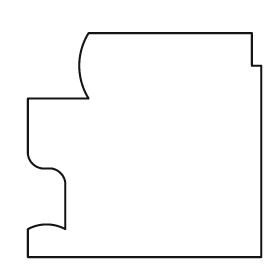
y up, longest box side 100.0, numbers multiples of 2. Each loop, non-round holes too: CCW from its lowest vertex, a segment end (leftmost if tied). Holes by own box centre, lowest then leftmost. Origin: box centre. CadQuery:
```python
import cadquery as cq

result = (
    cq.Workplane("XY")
    .moveTo(-50.0, -48.0)
    .lineTo(50.0, -48.0)
    .lineTo(50.0, 34.0)
    .lineTo(46.0, 34.0)
    .lineTo(46.0, 48.0)
    .lineTo(-24.0, 48.0)
    .threePointArc((-28.0, 34.0), (-24.0, 20.0))
    .lineTo(-50.0, 20.0)
    .lineTo(-50.0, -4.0)
    .threePointArc((-48.0, -8.0), (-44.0, -10.0))
    .lineTo(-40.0, -10.0)
    .threePointArc((-36.0, -12.0), (-34.0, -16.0))
    .lineTo(-34.0, -36.0)
    .threePointArc((-42.0, -34.0), (-50.0, -36.0))
    .close()
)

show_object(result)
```